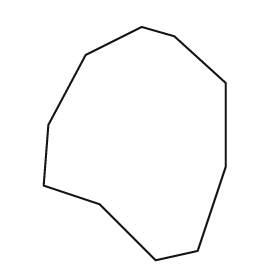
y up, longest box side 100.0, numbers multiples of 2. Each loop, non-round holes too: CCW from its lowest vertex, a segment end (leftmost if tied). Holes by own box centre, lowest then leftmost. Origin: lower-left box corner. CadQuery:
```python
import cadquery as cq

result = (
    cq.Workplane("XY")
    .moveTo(48.0, 0.0)
    .lineTo(66.0, 4.0)
    .lineTo(78.0, 40.0)
    .lineTo(78.0, 76.0)
    .lineTo(56.0, 96.0)
    .lineTo(42.0, 100.0)
    .lineTo(18.0, 88.0)
    .lineTo(2.0, 58.0)
    .lineTo(0.0, 32.0)
    .lineTo(24.0, 24.0)
    .close()
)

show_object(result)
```